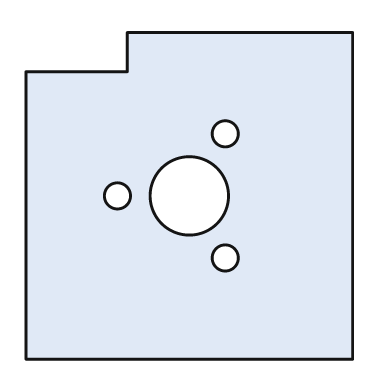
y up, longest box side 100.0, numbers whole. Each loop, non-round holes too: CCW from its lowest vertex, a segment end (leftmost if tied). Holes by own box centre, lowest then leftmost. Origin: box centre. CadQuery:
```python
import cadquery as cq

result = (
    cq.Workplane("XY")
    .moveTo(-50.0, -50.0)
    .lineTo(50.0, -50.0)
    .lineTo(50.0, 50.0)
    .lineTo(-19.0, 50.0)
    .lineTo(-19.0, 38.0)
    .lineTo(-50.0, 38.0)
    .close()
    .moveTo(11.0, -19.0)
    .circle(4.0)
    .moveTo(-22.0, 0.0)
    .circle(4.0)
    .moveTo(0.0, 0.0)
    .circle(12.0)
    .moveTo(11.0, 19.0)
    .circle(4.0)
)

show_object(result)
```